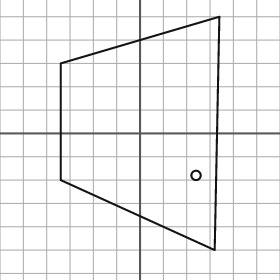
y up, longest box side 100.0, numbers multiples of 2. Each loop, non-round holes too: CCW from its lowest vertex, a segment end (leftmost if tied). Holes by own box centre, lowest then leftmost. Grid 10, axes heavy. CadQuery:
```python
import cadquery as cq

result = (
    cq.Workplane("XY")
    .moveTo(32.0, -50.0)
    .lineTo(34.0, 50.0)
    .lineTo(-34.0, 30.0)
    .lineTo(-34.0, -20.0)
    .close()
    .moveTo(24.0, -18.0)
    .circle(2.0)
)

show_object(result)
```